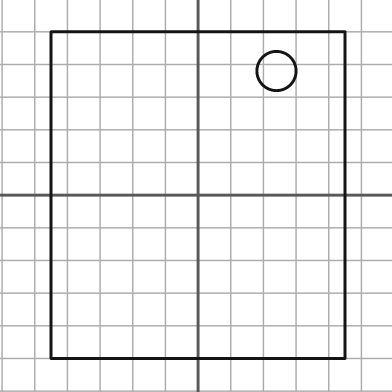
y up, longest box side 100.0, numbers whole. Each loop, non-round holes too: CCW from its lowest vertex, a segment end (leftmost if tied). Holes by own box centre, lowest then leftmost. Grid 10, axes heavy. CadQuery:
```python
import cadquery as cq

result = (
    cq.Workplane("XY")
    .moveTo(-45.0, -50.0)
    .lineTo(45.0, -50.0)
    .lineTo(45.0, 50.0)
    .lineTo(-45.0, 50.0)
    .close()
    .moveTo(24.0, 38.0)
    .circle(6.0)
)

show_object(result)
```